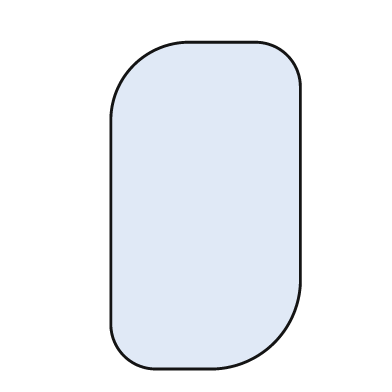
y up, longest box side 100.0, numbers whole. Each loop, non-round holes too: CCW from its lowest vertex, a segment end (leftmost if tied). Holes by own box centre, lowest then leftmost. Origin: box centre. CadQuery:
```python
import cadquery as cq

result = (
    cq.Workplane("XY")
    .moveTo(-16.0, -50.0)
    .lineTo(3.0, -50.0)
    .threePointArc((21.0, -42.0), (29.0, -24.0))
    .lineTo(29.0, 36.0)
    .threePointArc((25.0, 46.0), (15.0, 50.0))
    .lineTo(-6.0, 50.0)
    .threePointArc((-22.0, 43.0), (-29.0, 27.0))
    .lineTo(-29.0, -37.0)
    .threePointArc((-25.0, -46.0), (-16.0, -50.0))
    .close()
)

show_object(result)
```